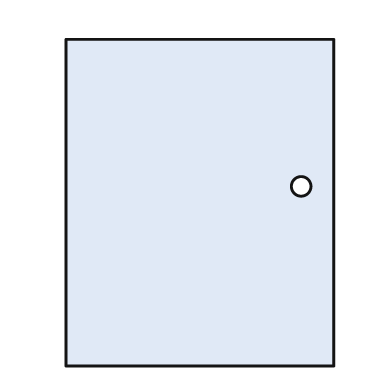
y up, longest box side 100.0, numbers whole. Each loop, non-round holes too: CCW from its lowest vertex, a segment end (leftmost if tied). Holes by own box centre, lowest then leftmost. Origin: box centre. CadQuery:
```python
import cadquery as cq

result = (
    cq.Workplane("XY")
    .moveTo(-41.0, -50.0)
    .lineTo(41.0, -50.0)
    .lineTo(41.0, 50.0)
    .lineTo(-41.0, 50.0)
    .close()
    .moveTo(31.0, 5.0)
    .circle(3.0)
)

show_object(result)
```